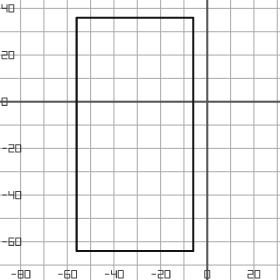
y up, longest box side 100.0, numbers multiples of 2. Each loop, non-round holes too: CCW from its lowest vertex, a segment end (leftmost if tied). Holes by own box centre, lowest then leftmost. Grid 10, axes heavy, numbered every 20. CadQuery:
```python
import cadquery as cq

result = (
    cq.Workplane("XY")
    .moveTo(-56.0, -64.0)
    .lineTo(-6.0, -64.0)
    .lineTo(-6.0, 36.0)
    .lineTo(-56.0, 36.0)
    .close()
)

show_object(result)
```